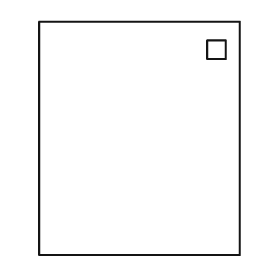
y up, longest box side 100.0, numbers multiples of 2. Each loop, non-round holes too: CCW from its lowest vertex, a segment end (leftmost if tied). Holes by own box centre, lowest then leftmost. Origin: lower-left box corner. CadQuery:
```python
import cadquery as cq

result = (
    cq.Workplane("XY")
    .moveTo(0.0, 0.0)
    .lineTo(86.0, 0.0)
    .lineTo(86.0, 100.0)
    .lineTo(0.0, 100.0)
    .close()
    .moveTo(72.0, 84.0)
    .lineTo(80.0, 84.0)
    .lineTo(80.0, 92.0)
    .lineTo(72.0, 92.0)
    .close()
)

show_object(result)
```